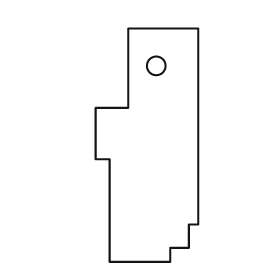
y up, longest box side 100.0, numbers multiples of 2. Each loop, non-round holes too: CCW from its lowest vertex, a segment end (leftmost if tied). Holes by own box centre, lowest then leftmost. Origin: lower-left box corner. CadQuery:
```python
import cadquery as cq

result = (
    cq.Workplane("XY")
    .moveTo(6.0, 0.0)
    .lineTo(32.0, 0.0)
    .lineTo(32.0, 6.0)
    .lineTo(40.0, 6.0)
    .lineTo(40.0, 16.0)
    .lineTo(44.0, 16.0)
    .lineTo(44.0, 100.0)
    .lineTo(14.0, 100.0)
    .lineTo(14.0, 66.0)
    .lineTo(0.0, 66.0)
    .lineTo(0.0, 44.0)
    .lineTo(6.0, 44.0)
    .close()
    .moveTo(26.0, 84.0)
    .circle(4.0)
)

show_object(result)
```